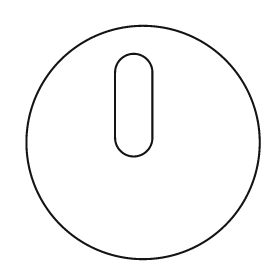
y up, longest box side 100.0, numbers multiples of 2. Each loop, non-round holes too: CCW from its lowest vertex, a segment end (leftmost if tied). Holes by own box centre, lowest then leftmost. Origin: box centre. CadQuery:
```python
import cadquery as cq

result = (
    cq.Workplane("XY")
    .moveTo(0.0, 0.0)
    .circle(50.0)
    .moveTo(-12.0, 2.0)
    .threePointArc((-4.0, -6.0), (4.0, 2.0))
    .lineTo(4.0, 30.0)
    .threePointArc((-4.0, 38.0), (-12.0, 30.0))
    .close()
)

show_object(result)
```